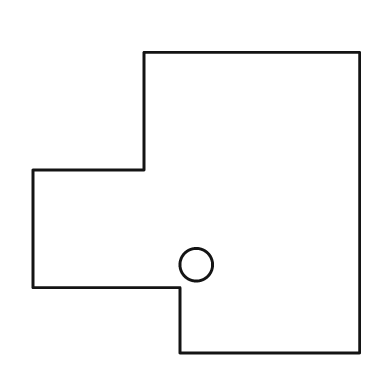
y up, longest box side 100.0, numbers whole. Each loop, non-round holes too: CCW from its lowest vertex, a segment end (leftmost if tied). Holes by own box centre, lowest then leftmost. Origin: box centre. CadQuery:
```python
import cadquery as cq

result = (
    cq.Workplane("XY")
    .moveTo(-5.0, -46.0)
    .lineTo(50.0, -46.0)
    .lineTo(50.0, 46.0)
    .lineTo(-16.0, 46.0)
    .lineTo(-16.0, 10.0)
    .lineTo(-50.0, 10.0)
    .lineTo(-50.0, -26.0)
    .lineTo(-5.0, -26.0)
    .close()
    .moveTo(0.0, -19.0)
    .circle(5.0)
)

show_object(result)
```